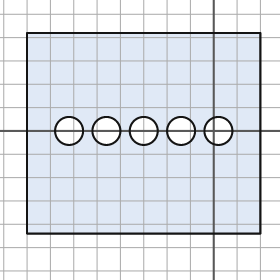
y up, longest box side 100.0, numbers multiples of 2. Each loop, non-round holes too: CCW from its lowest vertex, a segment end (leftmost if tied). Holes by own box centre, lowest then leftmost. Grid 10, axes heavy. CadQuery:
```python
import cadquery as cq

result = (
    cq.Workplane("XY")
    .moveTo(-80.0, -44.0)
    .lineTo(20.0, -44.0)
    .lineTo(20.0, 42.0)
    .lineTo(-80.0, 42.0)
    .close()
    .moveTo(-62.0, 0.0)
    .circle(6.0)
    .moveTo(-46.0, 0.0)
    .circle(6.0)
    .moveTo(-30.0, 0.0)
    .circle(6.0)
    .moveTo(-14.0, 0.0)
    .circle(6.0)
    .moveTo(2.0, 0.0)
    .circle(6.0)
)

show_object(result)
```